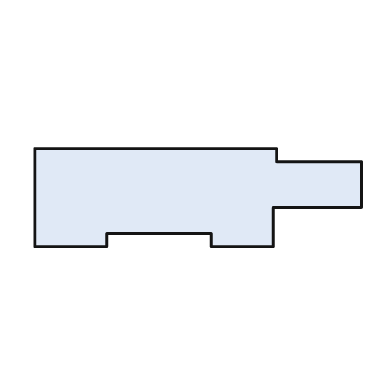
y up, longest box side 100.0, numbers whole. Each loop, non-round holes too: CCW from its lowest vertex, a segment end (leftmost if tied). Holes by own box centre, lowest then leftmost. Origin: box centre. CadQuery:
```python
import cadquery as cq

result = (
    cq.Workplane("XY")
    .moveTo(-50.0, -15.0)
    .lineTo(-28.0, -15.0)
    .lineTo(-28.0, -11.0)
    .lineTo(4.0, -11.0)
    .lineTo(4.0, -15.0)
    .lineTo(23.0, -15.0)
    .lineTo(23.0, -3.0)
    .lineTo(50.0, -3.0)
    .lineTo(50.0, 11.0)
    .lineTo(24.0, 11.0)
    .lineTo(24.0, 15.0)
    .lineTo(-50.0, 15.0)
    .close()
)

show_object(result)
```